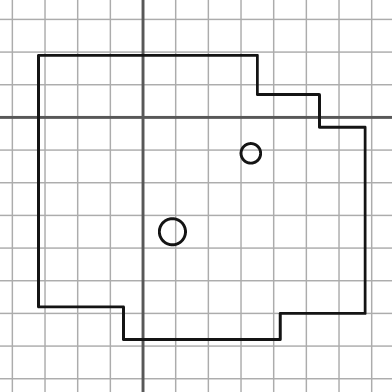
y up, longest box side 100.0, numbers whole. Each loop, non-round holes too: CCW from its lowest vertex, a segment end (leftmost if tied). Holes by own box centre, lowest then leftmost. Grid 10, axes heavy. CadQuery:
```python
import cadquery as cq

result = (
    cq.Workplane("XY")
    .moveTo(-6.0, -68.0)
    .lineTo(42.0, -68.0)
    .lineTo(42.0, -60.0)
    .lineTo(68.0, -60.0)
    .lineTo(68.0, -3.0)
    .lineTo(54.0, -3.0)
    .lineTo(54.0, 7.0)
    .lineTo(35.0, 7.0)
    .lineTo(35.0, 19.0)
    .lineTo(-32.0, 19.0)
    .lineTo(-32.0, -58.0)
    .lineTo(-6.0, -58.0)
    .close()
    .moveTo(9.0, -35.0)
    .circle(4.0)
    .moveTo(33.0, -11.0)
    .circle(3.0)
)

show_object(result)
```